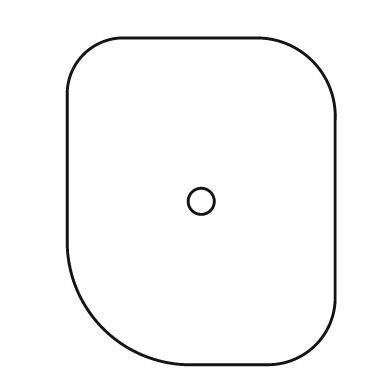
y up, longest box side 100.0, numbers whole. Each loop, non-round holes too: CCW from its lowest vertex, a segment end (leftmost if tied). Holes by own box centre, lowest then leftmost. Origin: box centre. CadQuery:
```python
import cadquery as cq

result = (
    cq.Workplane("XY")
    .moveTo(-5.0, -50.0)
    .lineTo(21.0, -50.0)
    .threePointArc((35.0, -44.0), (41.0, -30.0))
    .lineTo(41.0, 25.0)
    .threePointArc((34.0, 43.0), (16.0, 50.0))
    .lineTo(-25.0, 50.0)
    .threePointArc((-36.0, 45.0), (-41.0, 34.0))
    .lineTo(-41.0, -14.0)
    .threePointArc((-30.0, -39.0), (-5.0, -50.0))
    .close()
    .moveTo(0.0, 0.0)
    .circle(4.0)
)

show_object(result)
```